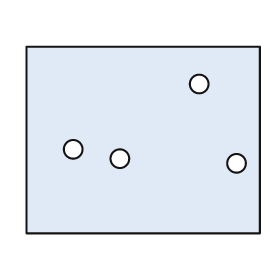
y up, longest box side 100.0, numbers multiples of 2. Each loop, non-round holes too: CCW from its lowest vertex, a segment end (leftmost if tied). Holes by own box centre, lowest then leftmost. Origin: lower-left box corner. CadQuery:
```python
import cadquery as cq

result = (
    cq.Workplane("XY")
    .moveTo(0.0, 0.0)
    .lineTo(100.0, 0.0)
    .lineTo(100.0, 80.0)
    .lineTo(0.0, 80.0)
    .close()
    .moveTo(90.0, 30.0)
    .circle(4.0)
    .moveTo(40.0, 32.0)
    .circle(4.0)
    .moveTo(20.0, 36.0)
    .circle(4.0)
    .moveTo(74.0, 64.0)
    .circle(4.0)
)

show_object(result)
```